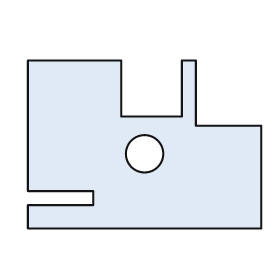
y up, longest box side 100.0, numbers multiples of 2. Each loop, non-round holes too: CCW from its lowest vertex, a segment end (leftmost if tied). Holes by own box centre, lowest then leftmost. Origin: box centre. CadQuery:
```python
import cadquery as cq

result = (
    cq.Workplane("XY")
    .moveTo(-50.0, -36.0)
    .lineTo(50.0, -36.0)
    .lineTo(50.0, 8.0)
    .lineTo(22.0, 8.0)
    .lineTo(22.0, 36.0)
    .lineTo(16.0, 36.0)
    .lineTo(16.0, 12.0)
    .lineTo(-10.0, 12.0)
    .lineTo(-10.0, 36.0)
    .lineTo(-50.0, 36.0)
    .lineTo(-50.0, -20.0)
    .lineTo(-22.0, -20.0)
    .lineTo(-22.0, -26.0)
    .lineTo(-50.0, -26.0)
    .close()
    .moveTo(0.0, -4.0)
    .circle(8.0)
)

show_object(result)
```